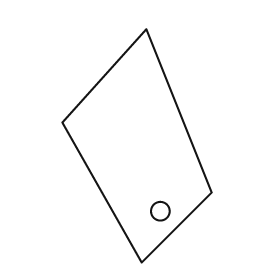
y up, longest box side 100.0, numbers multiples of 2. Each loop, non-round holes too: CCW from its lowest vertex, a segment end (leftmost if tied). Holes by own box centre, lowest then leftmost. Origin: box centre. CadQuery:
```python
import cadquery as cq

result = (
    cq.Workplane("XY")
    .moveTo(2.0, -50.0)
    .lineTo(32.0, -20.0)
    .lineTo(4.0, 50.0)
    .lineTo(-32.0, 10.0)
    .close()
    .moveTo(10.0, -28.0)
    .circle(4.0)
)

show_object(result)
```